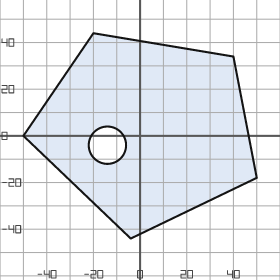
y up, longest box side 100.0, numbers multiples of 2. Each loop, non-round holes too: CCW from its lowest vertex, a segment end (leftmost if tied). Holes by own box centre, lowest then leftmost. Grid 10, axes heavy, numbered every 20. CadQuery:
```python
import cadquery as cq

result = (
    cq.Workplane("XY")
    .moveTo(-4.0, -44.0)
    .lineTo(50.0, -18.0)
    .lineTo(40.0, 34.0)
    .lineTo(-20.0, 44.0)
    .lineTo(-50.0, 0.0)
    .close()
    .moveTo(-14.0, -4.0)
    .circle(8.0)
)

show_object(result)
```